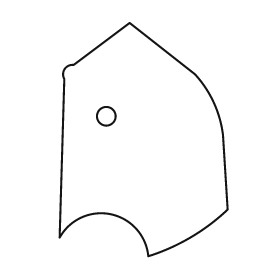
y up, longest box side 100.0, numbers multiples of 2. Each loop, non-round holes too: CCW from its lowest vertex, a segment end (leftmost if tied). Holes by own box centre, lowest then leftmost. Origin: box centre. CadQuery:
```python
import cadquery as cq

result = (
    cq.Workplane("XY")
    .moveTo(2.0, -50.0)
    .threePointArc((20.0, -42.0), (36.0, -30.0))
    .lineTo(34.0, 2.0)
    .threePointArc((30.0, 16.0), (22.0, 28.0))
    .lineTo(-6.0, 50.0)
    .lineTo(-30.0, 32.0)
    .threePointArc((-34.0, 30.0), (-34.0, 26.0))
    .lineTo(-36.0, -42.0)
    .threePointArc((-14.0, -32.0), (2.0, -50.0))
    .close()
    .moveTo(-16.0, 10.0)
    .circle(4.0)
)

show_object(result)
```